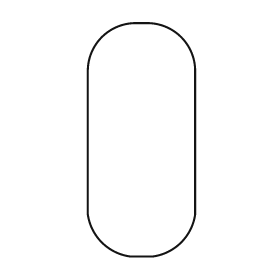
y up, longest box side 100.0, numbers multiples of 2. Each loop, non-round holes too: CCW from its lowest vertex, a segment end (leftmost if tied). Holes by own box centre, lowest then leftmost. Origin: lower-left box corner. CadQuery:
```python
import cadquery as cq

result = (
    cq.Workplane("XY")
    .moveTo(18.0, 0.0)
    .lineTo(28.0, 0.0)
    .threePointArc((40.0, 6.0), (46.0, 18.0))
    .lineTo(46.0, 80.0)
    .threePointArc((40.0, 94.0), (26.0, 100.0))
    .lineTo(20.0, 100.0)
    .threePointArc((6.0, 94.0), (0.0, 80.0))
    .lineTo(0.0, 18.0)
    .threePointArc((6.0, 6.0), (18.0, 0.0))
    .close()
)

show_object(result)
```